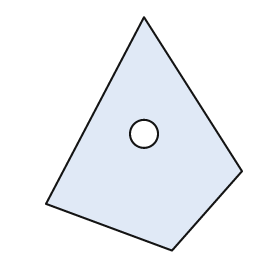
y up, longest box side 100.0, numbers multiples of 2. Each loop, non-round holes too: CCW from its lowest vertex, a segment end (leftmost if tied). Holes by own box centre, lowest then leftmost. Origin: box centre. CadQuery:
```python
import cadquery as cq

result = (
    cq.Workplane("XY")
    .moveTo(12.0, -50.0)
    .lineTo(42.0, -16.0)
    .lineTo(0.0, 50.0)
    .lineTo(-42.0, -30.0)
    .close()
    .moveTo(0.0, 0.0)
    .circle(6.0)
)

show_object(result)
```